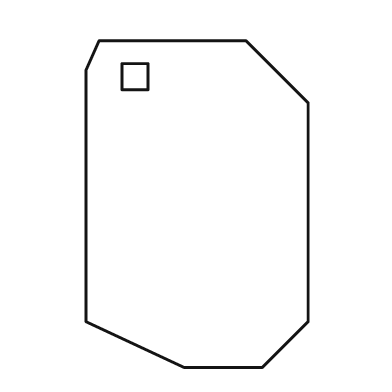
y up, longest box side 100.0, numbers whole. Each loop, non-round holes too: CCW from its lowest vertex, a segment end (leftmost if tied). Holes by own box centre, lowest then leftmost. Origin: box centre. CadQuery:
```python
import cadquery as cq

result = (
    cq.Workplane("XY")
    .moveTo(-4.0, -50.0)
    .lineTo(20.0, -50.0)
    .lineTo(34.0, -36.0)
    .lineTo(34.0, 31.0)
    .lineTo(15.0, 50.0)
    .lineTo(-30.0, 50.0)
    .lineTo(-34.0, 41.0)
    .lineTo(-34.0, -36.0)
    .close()
    .moveTo(-23.0, 35.0)
    .lineTo(-15.0, 35.0)
    .lineTo(-15.0, 43.0)
    .lineTo(-23.0, 43.0)
    .close()
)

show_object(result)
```